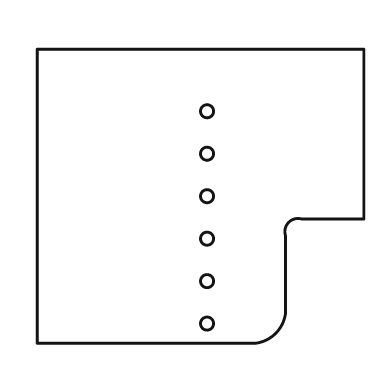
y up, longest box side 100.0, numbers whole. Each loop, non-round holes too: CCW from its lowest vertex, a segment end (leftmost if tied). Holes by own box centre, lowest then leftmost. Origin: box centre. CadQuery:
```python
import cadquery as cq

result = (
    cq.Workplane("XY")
    .moveTo(-50.0, -45.0)
    .lineTo(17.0, -45.0)
    .threePointArc((23.0, -42.0), (26.0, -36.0))
    .lineTo(26.0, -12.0)
    .threePointArc((27.0, -8.0), (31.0, -7.0))
    .lineTo(50.0, -7.0)
    .lineTo(50.0, 45.0)
    .lineTo(-50.0, 45.0)
    .close()
    .moveTo(2.0, -39.0)
    .circle(2.0)
    .moveTo(2.0, -26.0)
    .circle(2.0)
    .moveTo(2.0, -13.0)
    .circle(2.0)
    .moveTo(2.0, 0.0)
    .circle(2.0)
    .moveTo(2.0, 13.0)
    .circle(2.0)
    .moveTo(2.0, 26.0)
    .circle(2.0)
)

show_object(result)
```